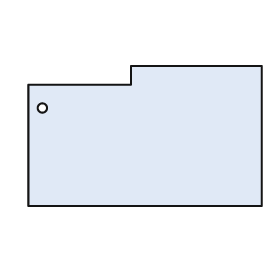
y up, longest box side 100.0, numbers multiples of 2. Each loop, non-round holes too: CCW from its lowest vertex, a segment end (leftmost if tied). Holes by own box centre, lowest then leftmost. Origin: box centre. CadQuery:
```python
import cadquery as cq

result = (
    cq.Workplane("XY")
    .moveTo(-50.0, -30.0)
    .lineTo(50.0, -30.0)
    .lineTo(50.0, 30.0)
    .lineTo(-6.0, 30.0)
    .lineTo(-6.0, 22.0)
    .lineTo(-50.0, 22.0)
    .close()
    .moveTo(-44.0, 12.0)
    .circle(2.0)
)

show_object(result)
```